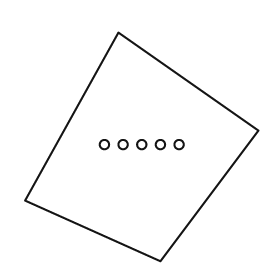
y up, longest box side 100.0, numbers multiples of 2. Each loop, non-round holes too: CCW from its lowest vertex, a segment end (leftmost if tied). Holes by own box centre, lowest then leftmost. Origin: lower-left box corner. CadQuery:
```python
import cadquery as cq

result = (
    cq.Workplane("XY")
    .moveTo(58.0, 0.0)
    .lineTo(100.0, 56.0)
    .lineTo(40.0, 98.0)
    .lineTo(0.0, 26.0)
    .close()
    .moveTo(34.0, 50.0)
    .circle(2.0)
    .moveTo(42.0, 50.0)
    .circle(2.0)
    .moveTo(50.0, 50.0)
    .circle(2.0)
    .moveTo(58.0, 50.0)
    .circle(2.0)
    .moveTo(66.0, 50.0)
    .circle(2.0)
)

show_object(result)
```